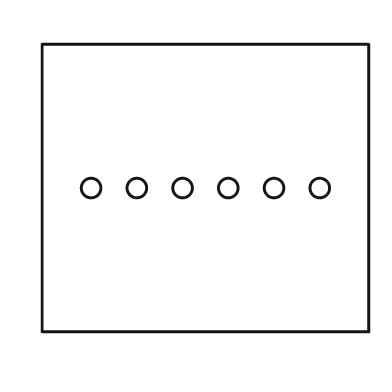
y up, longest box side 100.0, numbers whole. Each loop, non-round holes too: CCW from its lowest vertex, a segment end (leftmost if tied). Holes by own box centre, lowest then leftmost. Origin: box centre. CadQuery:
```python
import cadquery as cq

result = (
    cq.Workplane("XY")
    .moveTo(-50.0, -44.0)
    .lineTo(50.0, -44.0)
    .lineTo(50.0, 44.0)
    .lineTo(-50.0, 44.0)
    .close()
    .moveTo(-35.0, 0.0)
    .circle(3.0)
    .moveTo(-21.0, 0.0)
    .circle(3.0)
    .moveTo(-7.0, 0.0)
    .circle(3.0)
    .moveTo(7.0, 0.0)
    .circle(3.0)
    .moveTo(21.0, 0.0)
    .circle(3.0)
    .moveTo(35.0, 0.0)
    .circle(3.0)
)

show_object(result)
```